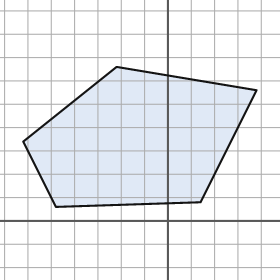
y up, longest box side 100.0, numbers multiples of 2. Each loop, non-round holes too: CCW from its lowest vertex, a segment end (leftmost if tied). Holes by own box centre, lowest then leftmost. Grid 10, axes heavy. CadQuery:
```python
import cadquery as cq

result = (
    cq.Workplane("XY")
    .moveTo(-48.0, 6.0)
    .lineTo(14.0, 8.0)
    .lineTo(38.0, 56.0)
    .lineTo(-22.0, 66.0)
    .lineTo(-62.0, 34.0)
    .close()
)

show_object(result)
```